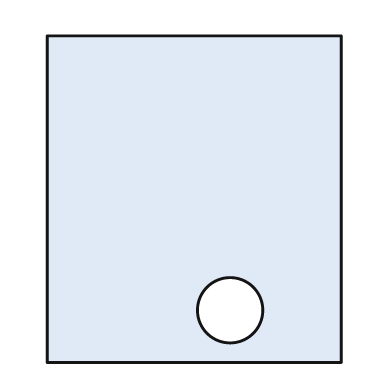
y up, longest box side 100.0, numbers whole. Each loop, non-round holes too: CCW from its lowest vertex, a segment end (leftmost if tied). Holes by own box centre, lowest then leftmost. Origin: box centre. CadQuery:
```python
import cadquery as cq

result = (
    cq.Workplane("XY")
    .moveTo(-45.0, -50.0)
    .lineTo(45.0, -50.0)
    .lineTo(45.0, 50.0)
    .lineTo(-45.0, 50.0)
    .close()
    .moveTo(11.0, -34.0)
    .circle(10.0)
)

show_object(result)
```